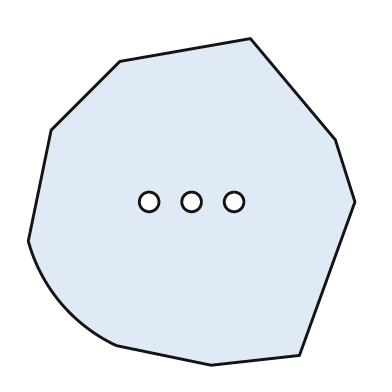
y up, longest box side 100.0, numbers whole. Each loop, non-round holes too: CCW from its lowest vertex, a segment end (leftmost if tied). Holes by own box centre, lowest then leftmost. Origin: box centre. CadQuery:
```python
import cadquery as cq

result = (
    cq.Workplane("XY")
    .moveTo(6.0, -50.0)
    .lineTo(33.0, -47.0)
    .lineTo(50.0, 0.0)
    .lineTo(44.0, 19.0)
    .lineTo(18.0, 50.0)
    .lineTo(-22.0, 43.0)
    .lineTo(-43.0, 22.0)
    .lineTo(-50.0, -12.0)
    .threePointArc((-40.0, -31.0), (-23.0, -44.0))
    .close()
    .moveTo(-13.0, 0.0)
    .circle(3.0)
    .moveTo(0.0, 0.0)
    .circle(3.0)
    .moveTo(13.0, 0.0)
    .circle(3.0)
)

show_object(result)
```